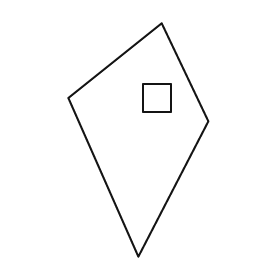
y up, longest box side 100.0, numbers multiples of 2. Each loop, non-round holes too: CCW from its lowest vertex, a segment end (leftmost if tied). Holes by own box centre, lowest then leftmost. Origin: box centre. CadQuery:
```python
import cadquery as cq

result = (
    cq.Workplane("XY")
    .moveTo(0.0, -50.0)
    .lineTo(30.0, 8.0)
    .lineTo(10.0, 50.0)
    .lineTo(-30.0, 18.0)
    .close()
    .moveTo(2.0, 12.0)
    .lineTo(14.0, 12.0)
    .lineTo(14.0, 24.0)
    .lineTo(2.0, 24.0)
    .close()
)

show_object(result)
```